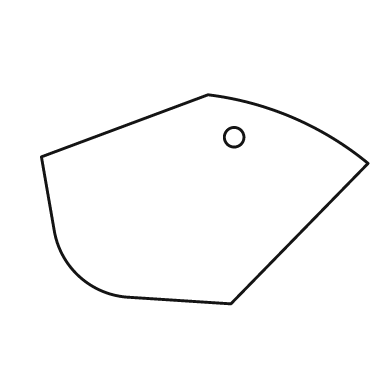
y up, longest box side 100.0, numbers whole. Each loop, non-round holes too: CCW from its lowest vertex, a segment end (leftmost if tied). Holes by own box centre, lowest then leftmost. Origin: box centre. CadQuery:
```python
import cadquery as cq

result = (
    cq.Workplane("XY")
    .moveTo(8.0, -32.0)
    .lineTo(50.0, 11.0)
    .threePointArc((27.0, 25.0), (1.0, 32.0))
    .lineTo(-50.0, 13.0)
    .lineTo(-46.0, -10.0)
    .threePointArc((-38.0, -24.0), (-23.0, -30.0))
    .close()
    .moveTo(9.0, 19.0)
    .circle(3.0)
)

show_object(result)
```